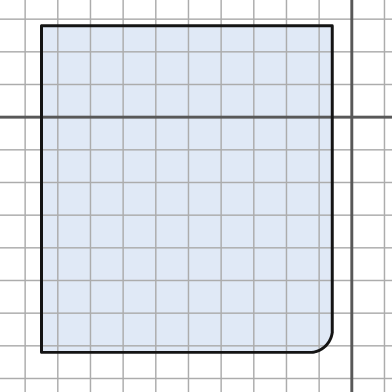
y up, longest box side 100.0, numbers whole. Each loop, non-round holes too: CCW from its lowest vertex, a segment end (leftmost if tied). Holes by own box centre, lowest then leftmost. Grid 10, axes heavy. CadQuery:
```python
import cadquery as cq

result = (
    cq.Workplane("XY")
    .moveTo(-95.0, -72.0)
    .lineTo(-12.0, -72.0)
    .threePointArc((-8.0, -70.0), (-6.0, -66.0))
    .lineTo(-6.0, 28.0)
    .lineTo(-95.0, 28.0)
    .close()
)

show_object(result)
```